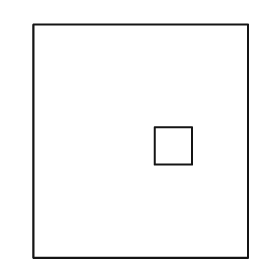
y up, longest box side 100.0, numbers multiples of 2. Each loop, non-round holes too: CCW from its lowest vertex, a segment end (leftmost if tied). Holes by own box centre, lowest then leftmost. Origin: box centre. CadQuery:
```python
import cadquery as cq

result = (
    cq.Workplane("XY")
    .moveTo(-46.0, -50.0)
    .lineTo(46.0, -50.0)
    .lineTo(46.0, 50.0)
    .lineTo(-46.0, 50.0)
    .close()
    .moveTo(6.0, -10.0)
    .lineTo(22.0, -10.0)
    .lineTo(22.0, 6.0)
    .lineTo(6.0, 6.0)
    .close()
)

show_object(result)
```